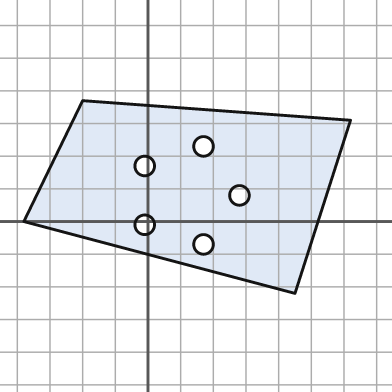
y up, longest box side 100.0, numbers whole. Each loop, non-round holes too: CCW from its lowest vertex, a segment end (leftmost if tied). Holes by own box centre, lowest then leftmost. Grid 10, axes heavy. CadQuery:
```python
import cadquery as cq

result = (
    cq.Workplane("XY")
    .moveTo(45.0, -22.0)
    .lineTo(62.0, 31.0)
    .lineTo(-20.0, 37.0)
    .lineTo(-38.0, 0.0)
    .close()
    .moveTo(17.0, -7.0)
    .circle(3.0)
    .moveTo(-1.0, -1.0)
    .circle(3.0)
    .moveTo(28.0, 8.0)
    .circle(3.0)
    .moveTo(-1.0, 17.0)
    .circle(3.0)
    .moveTo(17.0, 23.0)
    .circle(3.0)
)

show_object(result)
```